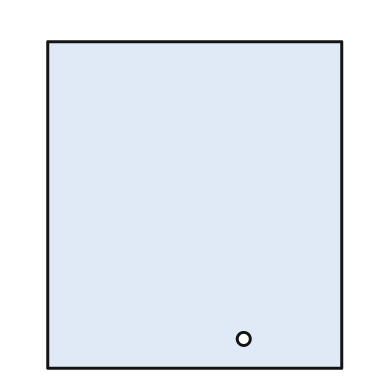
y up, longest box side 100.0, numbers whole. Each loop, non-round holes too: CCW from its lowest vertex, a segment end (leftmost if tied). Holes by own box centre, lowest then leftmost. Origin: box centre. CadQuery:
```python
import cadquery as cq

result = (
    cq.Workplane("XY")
    .moveTo(-45.0, -50.0)
    .lineTo(45.0, -50.0)
    .lineTo(45.0, 50.0)
    .lineTo(-45.0, 50.0)
    .close()
    .moveTo(15.0, -41.0)
    .circle(2.0)
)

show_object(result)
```